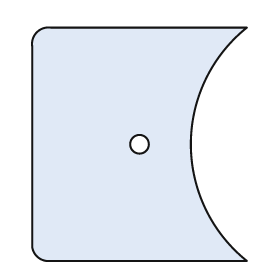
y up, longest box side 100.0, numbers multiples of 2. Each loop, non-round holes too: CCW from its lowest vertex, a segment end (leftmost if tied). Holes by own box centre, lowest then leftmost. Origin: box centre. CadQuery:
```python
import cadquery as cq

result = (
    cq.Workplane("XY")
    .moveTo(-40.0, -50.0)
    .lineTo(46.0, -50.0)
    .threePointArc((22.0, 0.0), (46.0, 50.0))
    .lineTo(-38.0, 50.0)
    .threePointArc((-44.0, 48.0), (-46.0, 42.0))
    .lineTo(-46.0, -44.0)
    .threePointArc((-44.0, -48.0), (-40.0, -50.0))
    .close()
    .moveTo(0.0, 0.0)
    .circle(4.0)
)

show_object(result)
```